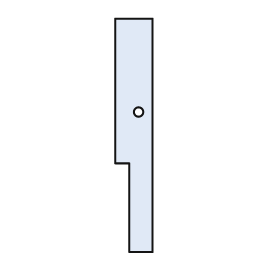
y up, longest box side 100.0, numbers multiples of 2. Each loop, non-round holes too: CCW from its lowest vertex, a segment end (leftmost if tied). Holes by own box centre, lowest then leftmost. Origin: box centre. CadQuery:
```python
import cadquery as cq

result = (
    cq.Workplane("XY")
    .moveTo(-2.0, -50.0)
    .lineTo(8.0, -50.0)
    .lineTo(8.0, 50.0)
    .lineTo(-8.0, 50.0)
    .lineTo(-8.0, -12.0)
    .lineTo(-2.0, -12.0)
    .close()
    .moveTo(2.0, 10.0)
    .circle(2.0)
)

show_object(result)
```